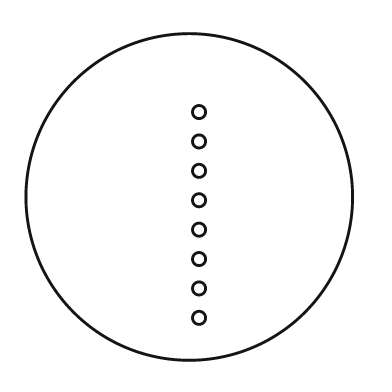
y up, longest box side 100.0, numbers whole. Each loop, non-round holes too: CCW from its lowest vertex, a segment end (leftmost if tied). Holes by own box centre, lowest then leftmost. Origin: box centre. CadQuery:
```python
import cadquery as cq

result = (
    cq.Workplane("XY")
    .moveTo(0.0, 0.0)
    .circle(50.0)
    .moveTo(3.0, -37.0)
    .circle(2.0)
    .moveTo(3.0, -28.0)
    .circle(2.0)
    .moveTo(3.0, -19.0)
    .circle(2.0)
    .moveTo(3.0, -10.0)
    .circle(2.0)
    .moveTo(3.0, -1.0)
    .circle(2.0)
    .moveTo(3.0, 8.0)
    .circle(2.0)
    .moveTo(3.0, 17.0)
    .circle(2.0)
    .moveTo(3.0, 26.0)
    .circle(2.0)
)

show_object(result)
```